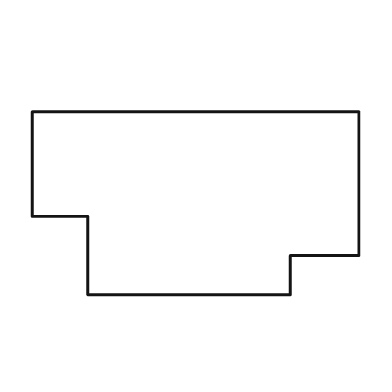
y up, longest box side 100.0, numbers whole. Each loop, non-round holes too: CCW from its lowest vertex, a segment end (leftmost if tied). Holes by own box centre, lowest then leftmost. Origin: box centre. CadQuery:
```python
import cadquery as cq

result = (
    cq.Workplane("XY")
    .moveTo(-33.0, -28.0)
    .lineTo(29.0, -28.0)
    .lineTo(29.0, -16.0)
    .lineTo(50.0, -16.0)
    .lineTo(50.0, 28.0)
    .lineTo(-50.0, 28.0)
    .lineTo(-50.0, -4.0)
    .lineTo(-33.0, -4.0)
    .close()
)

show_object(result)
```